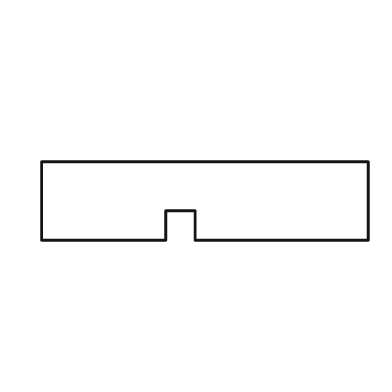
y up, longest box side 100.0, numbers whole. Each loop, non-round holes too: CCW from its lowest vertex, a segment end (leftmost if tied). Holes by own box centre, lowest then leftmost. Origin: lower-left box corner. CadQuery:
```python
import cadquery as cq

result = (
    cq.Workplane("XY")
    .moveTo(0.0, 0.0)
    .lineTo(38.0, 0.0)
    .lineTo(38.0, 9.0)
    .lineTo(47.0, 9.0)
    .lineTo(47.0, 0.0)
    .lineTo(100.0, 0.0)
    .lineTo(100.0, 24.0)
    .lineTo(0.0, 24.0)
    .close()
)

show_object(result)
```